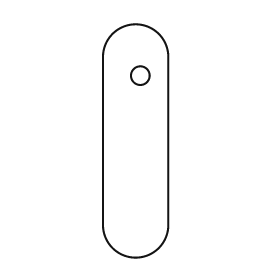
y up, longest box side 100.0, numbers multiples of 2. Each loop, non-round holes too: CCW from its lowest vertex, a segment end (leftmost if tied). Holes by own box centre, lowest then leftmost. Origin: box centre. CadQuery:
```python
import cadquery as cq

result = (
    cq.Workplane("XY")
    .moveTo(-14.0, -36.0)
    .threePointArc((0.0, -50.0), (14.0, -36.0))
    .lineTo(14.0, 36.0)
    .threePointArc((0.0, 50.0), (-14.0, 36.0))
    .close()
    .moveTo(2.0, 28.0)
    .circle(4.0)
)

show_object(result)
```